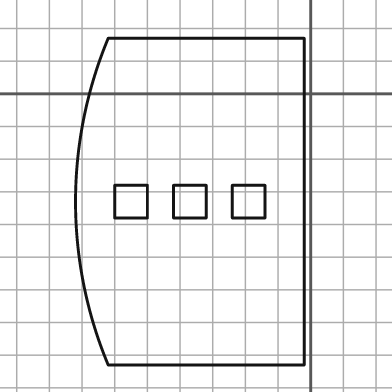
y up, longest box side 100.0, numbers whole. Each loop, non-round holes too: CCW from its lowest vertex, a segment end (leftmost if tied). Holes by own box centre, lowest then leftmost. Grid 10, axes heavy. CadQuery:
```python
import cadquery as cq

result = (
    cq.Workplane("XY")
    .moveTo(-62.0, -83.0)
    .lineTo(-2.0, -83.0)
    .lineTo(-2.0, 17.0)
    .lineTo(-62.0, 17.0)
    .threePointArc((-72.0, -33.0), (-62.0, -83.0))
    .close()
    .moveTo(-60.0, -38.0)
    .lineTo(-50.0, -38.0)
    .lineTo(-50.0, -28.0)
    .lineTo(-60.0, -28.0)
    .close()
    .moveTo(-42.0, -38.0)
    .lineTo(-32.0, -38.0)
    .lineTo(-32.0, -28.0)
    .lineTo(-42.0, -28.0)
    .close()
    .moveTo(-24.0, -38.0)
    .lineTo(-14.0, -38.0)
    .lineTo(-14.0, -28.0)
    .lineTo(-24.0, -28.0)
    .close()
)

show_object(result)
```